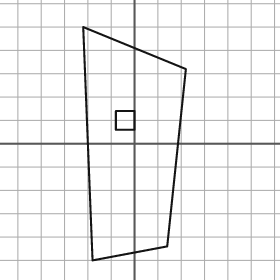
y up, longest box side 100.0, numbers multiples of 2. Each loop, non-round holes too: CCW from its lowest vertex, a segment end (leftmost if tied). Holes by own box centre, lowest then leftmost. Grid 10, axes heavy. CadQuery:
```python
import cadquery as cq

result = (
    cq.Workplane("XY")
    .moveTo(-18.0, -50.0)
    .lineTo(14.0, -44.0)
    .lineTo(22.0, 32.0)
    .lineTo(-22.0, 50.0)
    .close()
    .moveTo(-8.0, 6.0)
    .lineTo(0.0, 6.0)
    .lineTo(0.0, 14.0)
    .lineTo(-8.0, 14.0)
    .close()
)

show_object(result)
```